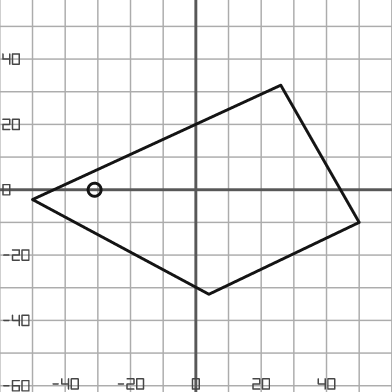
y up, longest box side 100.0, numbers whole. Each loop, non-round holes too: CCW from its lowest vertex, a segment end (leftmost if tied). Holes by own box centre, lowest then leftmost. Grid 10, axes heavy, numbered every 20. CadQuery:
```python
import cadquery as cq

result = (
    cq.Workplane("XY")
    .moveTo(4.0, -32.0)
    .lineTo(50.0, -10.0)
    .lineTo(26.0, 32.0)
    .lineTo(-50.0, -3.0)
    .close()
    .moveTo(-31.0, 0.0)
    .circle(2.0)
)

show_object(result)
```